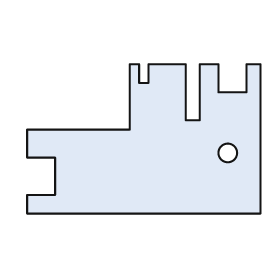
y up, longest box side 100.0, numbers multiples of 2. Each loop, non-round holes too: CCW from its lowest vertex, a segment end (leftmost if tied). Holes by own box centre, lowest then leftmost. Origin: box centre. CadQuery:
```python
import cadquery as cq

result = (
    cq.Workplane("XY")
    .moveTo(-50.0, -32.0)
    .lineTo(50.0, -32.0)
    .lineTo(50.0, 32.0)
    .lineTo(44.0, 32.0)
    .lineTo(44.0, 20.0)
    .lineTo(32.0, 20.0)
    .lineTo(32.0, 32.0)
    .lineTo(24.0, 32.0)
    .lineTo(24.0, 8.0)
    .lineTo(18.0, 8.0)
    .lineTo(18.0, 32.0)
    .lineTo(2.0, 32.0)
    .lineTo(2.0, 24.0)
    .lineTo(-2.0, 24.0)
    .lineTo(-2.0, 32.0)
    .lineTo(-6.0, 32.0)
    .lineTo(-6.0, 4.0)
    .lineTo(-50.0, 4.0)
    .lineTo(-50.0, -8.0)
    .lineTo(-38.0, -8.0)
    .lineTo(-38.0, -24.0)
    .lineTo(-50.0, -24.0)
    .close()
    .moveTo(36.0, -6.0)
    .circle(4.0)
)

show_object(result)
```